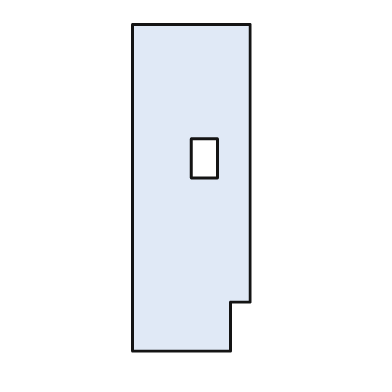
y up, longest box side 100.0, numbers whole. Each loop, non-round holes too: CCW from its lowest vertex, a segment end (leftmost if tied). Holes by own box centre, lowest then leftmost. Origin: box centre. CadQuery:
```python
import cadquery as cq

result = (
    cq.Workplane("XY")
    .moveTo(-18.0, -50.0)
    .lineTo(12.0, -50.0)
    .lineTo(12.0, -35.0)
    .lineTo(18.0, -35.0)
    .lineTo(18.0, 50.0)
    .lineTo(-18.0, 50.0)
    .close()
    .moveTo(0.0, 3.0)
    .lineTo(8.0, 3.0)
    .lineTo(8.0, 15.0)
    .lineTo(0.0, 15.0)
    .close()
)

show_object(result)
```